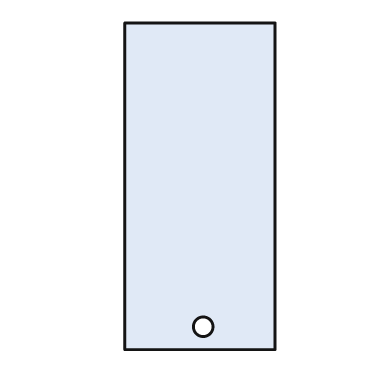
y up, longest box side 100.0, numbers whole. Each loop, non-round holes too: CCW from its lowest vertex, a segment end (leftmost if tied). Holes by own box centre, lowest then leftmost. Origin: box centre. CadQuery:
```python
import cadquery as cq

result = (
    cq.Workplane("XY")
    .moveTo(-23.0, -50.0)
    .lineTo(23.0, -50.0)
    .lineTo(23.0, 50.0)
    .lineTo(-23.0, 50.0)
    .close()
    .moveTo(1.0, -43.0)
    .circle(3.0)
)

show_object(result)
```